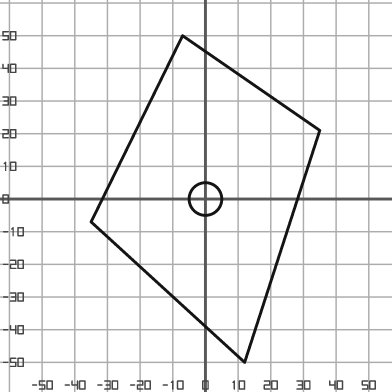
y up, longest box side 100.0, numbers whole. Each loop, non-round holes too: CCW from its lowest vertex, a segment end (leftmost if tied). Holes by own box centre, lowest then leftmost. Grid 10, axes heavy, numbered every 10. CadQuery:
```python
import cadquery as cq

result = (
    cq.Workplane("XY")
    .moveTo(12.0, -50.0)
    .lineTo(35.0, 21.0)
    .lineTo(-7.0, 50.0)
    .lineTo(-35.0, -7.0)
    .close()
    .moveTo(0.0, 0.0)
    .circle(5.0)
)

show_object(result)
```